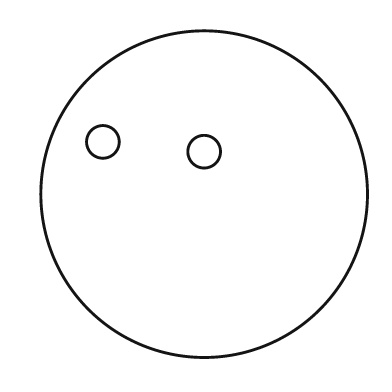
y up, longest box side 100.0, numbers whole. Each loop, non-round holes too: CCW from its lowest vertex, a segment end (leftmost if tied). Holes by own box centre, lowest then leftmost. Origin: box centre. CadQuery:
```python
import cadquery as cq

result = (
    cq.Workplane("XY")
    .moveTo(0.0, 0.0)
    .circle(50.0)
    .moveTo(0.0, 13.0)
    .circle(5.0)
    .moveTo(-31.0, 16.0)
    .circle(5.0)
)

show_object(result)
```